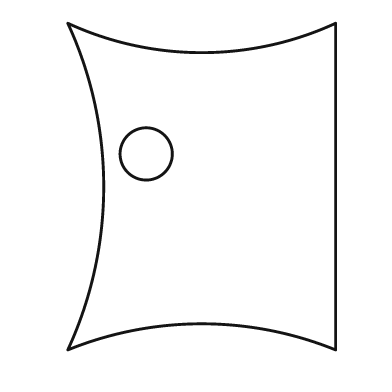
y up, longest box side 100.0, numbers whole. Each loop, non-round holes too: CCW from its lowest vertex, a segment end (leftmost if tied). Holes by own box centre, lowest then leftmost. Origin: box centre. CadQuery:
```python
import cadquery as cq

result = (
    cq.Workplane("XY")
    .moveTo(-41.0, -50.0)
    .threePointArc((0.0, -42.0), (41.0, -50.0))
    .lineTo(41.0, 50.0)
    .threePointArc((0.0, 41.0), (-41.0, 50.0))
    .threePointArc((-30.0, 0.0), (-41.0, -50.0))
    .close()
    .moveTo(-17.0, 10.0)
    .circle(8.0)
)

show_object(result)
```